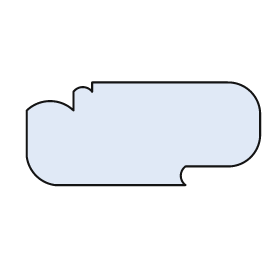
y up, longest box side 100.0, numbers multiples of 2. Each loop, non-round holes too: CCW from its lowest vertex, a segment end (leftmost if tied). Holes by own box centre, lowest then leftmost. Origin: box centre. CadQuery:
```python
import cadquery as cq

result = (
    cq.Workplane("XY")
    .moveTo(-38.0, -22.0)
    .lineTo(18.0, -22.0)
    .threePointArc((16.0, -18.0), (18.0, -14.0))
    .lineTo(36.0, -14.0)
    .threePointArc((46.0, -10.0), (50.0, 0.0))
    .lineTo(50.0, 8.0)
    .threePointArc((46.0, 18.0), (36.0, 22.0))
    .lineTo(-22.0, 22.0)
    .lineTo(-22.0, 18.0)
    .threePointArc((-26.0, 20.0), (-30.0, 18.0))
    .lineTo(-30.0, 10.0)
    .threePointArc((-40.0, 14.0), (-50.0, 10.0))
    .lineTo(-50.0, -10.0)
    .threePointArc((-46.0, -18.0), (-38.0, -22.0))
    .close()
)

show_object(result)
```